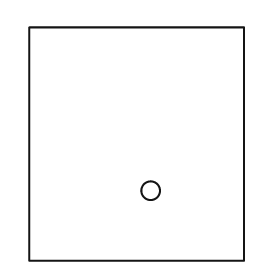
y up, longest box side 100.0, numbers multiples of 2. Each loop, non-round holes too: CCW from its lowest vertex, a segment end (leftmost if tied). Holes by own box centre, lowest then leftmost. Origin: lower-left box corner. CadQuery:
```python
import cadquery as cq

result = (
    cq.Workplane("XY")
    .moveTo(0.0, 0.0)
    .lineTo(92.0, 0.0)
    .lineTo(92.0, 100.0)
    .lineTo(0.0, 100.0)
    .close()
    .moveTo(52.0, 30.0)
    .circle(4.0)
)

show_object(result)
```